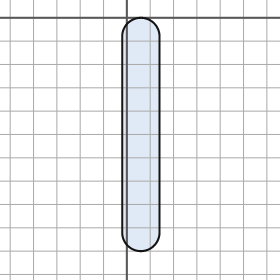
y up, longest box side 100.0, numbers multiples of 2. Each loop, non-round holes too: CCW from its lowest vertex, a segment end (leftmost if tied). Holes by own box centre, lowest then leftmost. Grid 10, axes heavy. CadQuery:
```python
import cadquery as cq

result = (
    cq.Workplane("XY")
    .moveTo(-2.0, -92.0)
    .threePointArc((6.0, -100.0), (14.0, -92.0))
    .lineTo(14.0, -8.0)
    .threePointArc((6.0, 0.0), (-2.0, -8.0))
    .close()
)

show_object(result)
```